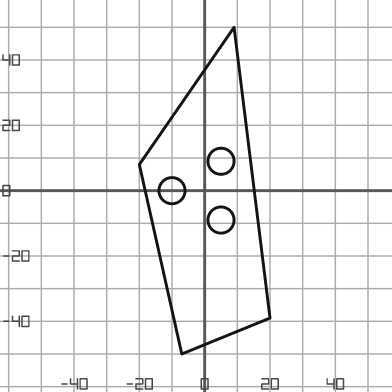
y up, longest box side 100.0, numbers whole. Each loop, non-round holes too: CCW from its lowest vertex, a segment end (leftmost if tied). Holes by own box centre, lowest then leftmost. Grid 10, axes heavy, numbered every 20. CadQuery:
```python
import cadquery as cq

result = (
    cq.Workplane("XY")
    .moveTo(-7.0, -50.0)
    .lineTo(20.0, -39.0)
    .lineTo(9.0, 50.0)
    .lineTo(-20.0, 8.0)
    .close()
    .moveTo(5.0, -9.0)
    .circle(4.0)
    .moveTo(-10.0, 0.0)
    .circle(4.0)
    .moveTo(5.0, 9.0)
    .circle(4.0)
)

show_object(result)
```